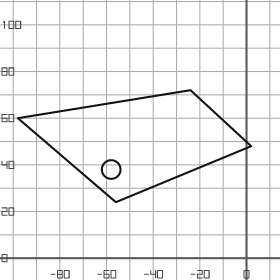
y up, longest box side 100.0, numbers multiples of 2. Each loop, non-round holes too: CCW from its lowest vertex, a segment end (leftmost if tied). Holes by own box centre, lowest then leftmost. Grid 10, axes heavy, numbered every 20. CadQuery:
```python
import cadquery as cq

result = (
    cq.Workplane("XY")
    .moveTo(-56.0, 24.0)
    .lineTo(2.0, 48.0)
    .lineTo(-24.0, 72.0)
    .lineTo(-98.0, 60.0)
    .close()
    .moveTo(-58.0, 38.0)
    .circle(4.0)
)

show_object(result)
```